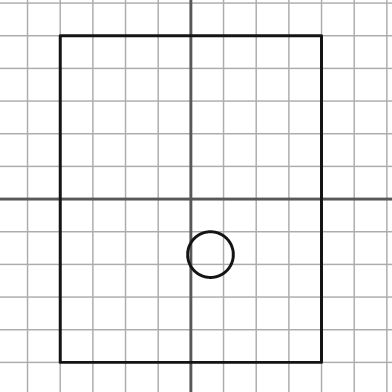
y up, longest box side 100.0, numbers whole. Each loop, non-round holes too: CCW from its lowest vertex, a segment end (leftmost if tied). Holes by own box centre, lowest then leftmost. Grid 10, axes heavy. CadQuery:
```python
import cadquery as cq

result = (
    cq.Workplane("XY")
    .moveTo(-40.0, -50.0)
    .lineTo(40.0, -50.0)
    .lineTo(40.0, 50.0)
    .lineTo(-40.0, 50.0)
    .close()
    .moveTo(6.0, -17.0)
    .circle(7.0)
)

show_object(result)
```